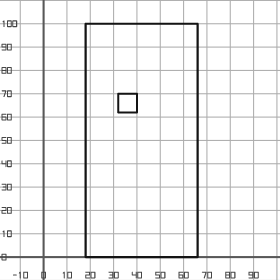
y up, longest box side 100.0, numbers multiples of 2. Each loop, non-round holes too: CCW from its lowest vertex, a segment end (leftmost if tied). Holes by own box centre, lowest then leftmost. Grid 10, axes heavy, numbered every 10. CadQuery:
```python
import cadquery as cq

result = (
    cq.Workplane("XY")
    .moveTo(18.0, 0.0)
    .lineTo(66.0, 0.0)
    .lineTo(66.0, 100.0)
    .lineTo(18.0, 100.0)
    .close()
    .moveTo(32.0, 62.0)
    .lineTo(40.0, 62.0)
    .lineTo(40.0, 70.0)
    .lineTo(32.0, 70.0)
    .close()
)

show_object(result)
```